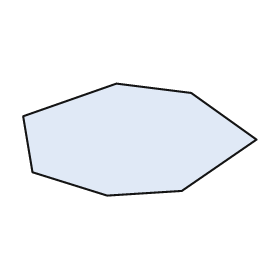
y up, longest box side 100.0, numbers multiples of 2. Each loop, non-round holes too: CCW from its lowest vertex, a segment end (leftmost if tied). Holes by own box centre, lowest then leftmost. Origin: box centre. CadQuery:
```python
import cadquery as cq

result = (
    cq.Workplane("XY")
    .moveTo(-14.0, -24.0)
    .lineTo(18.0, -22.0)
    .lineTo(50.0, 0.0)
    .lineTo(22.0, 20.0)
    .lineTo(-10.0, 24.0)
    .lineTo(-50.0, 10.0)
    .lineTo(-46.0, -14.0)
    .close()
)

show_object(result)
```